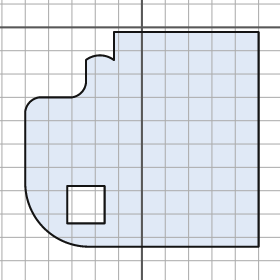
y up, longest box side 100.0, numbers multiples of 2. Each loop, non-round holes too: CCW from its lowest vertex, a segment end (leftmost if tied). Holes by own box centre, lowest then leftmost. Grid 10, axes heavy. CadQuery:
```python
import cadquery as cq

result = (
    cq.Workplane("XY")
    .moveTo(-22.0, -94.0)
    .lineTo(50.0, -94.0)
    .lineTo(50.0, -2.0)
    .lineTo(-12.0, -2.0)
    .lineTo(-12.0, -14.0)
    .threePointArc((-18.0, -12.0), (-24.0, -14.0))
    .lineTo(-24.0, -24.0)
    .threePointArc((-26.0, -28.0), (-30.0, -30.0))
    .lineTo(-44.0, -30.0)
    .threePointArc((-48.0, -32.0), (-50.0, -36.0))
    .lineTo(-50.0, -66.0)
    .threePointArc((-42.0, -86.0), (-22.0, -94.0))
    .close()
    .moveTo(-32.0, -84.0)
    .lineTo(-16.0, -84.0)
    .lineTo(-16.0, -68.0)
    .lineTo(-32.0, -68.0)
    .close()
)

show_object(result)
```